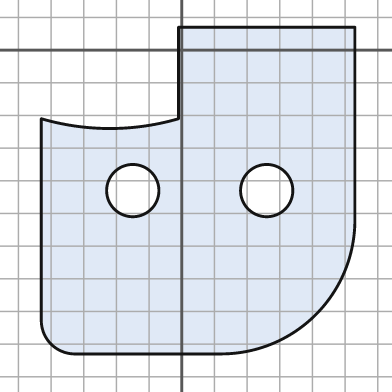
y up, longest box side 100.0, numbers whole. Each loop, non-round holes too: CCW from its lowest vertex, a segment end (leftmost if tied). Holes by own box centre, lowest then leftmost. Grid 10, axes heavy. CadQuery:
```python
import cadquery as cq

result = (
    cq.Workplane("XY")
    .moveTo(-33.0, -93.0)
    .lineTo(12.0, -93.0)
    .threePointArc((41.0, -81.0), (53.0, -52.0))
    .lineTo(53.0, 7.0)
    .lineTo(-1.0, 7.0)
    .lineTo(-1.0, -21.0)
    .threePointArc((-22.0, -24.0), (-43.0, -21.0))
    .lineTo(-43.0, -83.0)
    .threePointArc((-40.0, -90.0), (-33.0, -93.0))
    .close()
    .moveTo(-15.0, -43.0)
    .circle(8.0)
    .moveTo(26.0, -43.0)
    .circle(8.0)
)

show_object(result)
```